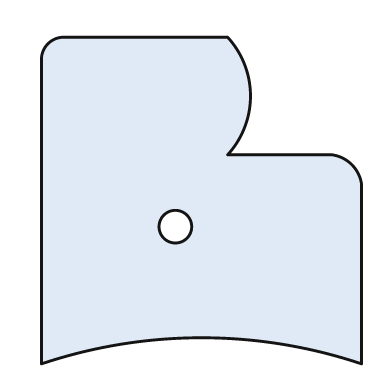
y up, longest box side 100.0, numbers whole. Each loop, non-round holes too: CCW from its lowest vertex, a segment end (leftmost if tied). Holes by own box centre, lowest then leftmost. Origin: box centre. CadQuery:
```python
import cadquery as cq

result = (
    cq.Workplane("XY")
    .moveTo(-49.0, -50.0)
    .threePointArc((0.0, -42.0), (49.0, -50.0))
    .lineTo(49.0, 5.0)
    .threePointArc((46.0, 11.0), (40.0, 14.0))
    .lineTo(8.0, 14.0)
    .threePointArc((15.0, 32.0), (8.0, 50.0))
    .lineTo(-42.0, 50.0)
    .threePointArc((-47.0, 48.0), (-49.0, 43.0))
    .close()
    .moveTo(-8.0, -8.0)
    .circle(5.0)
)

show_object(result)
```